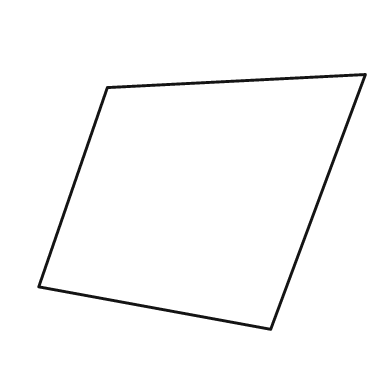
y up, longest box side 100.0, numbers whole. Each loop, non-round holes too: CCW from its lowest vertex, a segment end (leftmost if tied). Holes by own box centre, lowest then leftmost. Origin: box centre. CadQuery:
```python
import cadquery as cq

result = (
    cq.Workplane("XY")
    .moveTo(21.0, -39.0)
    .lineTo(50.0, 39.0)
    .lineTo(-29.0, 35.0)
    .lineTo(-50.0, -26.0)
    .close()
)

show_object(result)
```